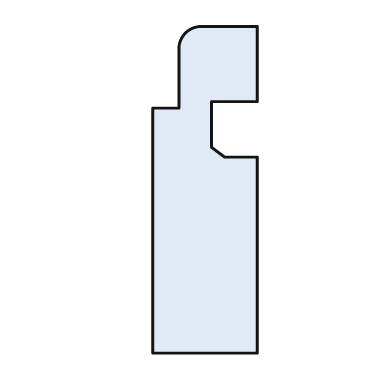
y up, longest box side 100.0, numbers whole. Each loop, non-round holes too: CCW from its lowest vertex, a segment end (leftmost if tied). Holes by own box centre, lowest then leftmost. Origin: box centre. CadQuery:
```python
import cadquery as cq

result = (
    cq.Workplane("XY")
    .moveTo(-16.0, -50.0)
    .lineTo(16.0, -50.0)
    .lineTo(16.0, 10.0)
    .lineTo(6.0, 10.0)
    .lineTo(2.0, 13.0)
    .lineTo(2.0, 27.0)
    .lineTo(16.0, 27.0)
    .lineTo(16.0, 50.0)
    .lineTo(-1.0, 50.0)
    .threePointArc((-6.0, 48.0), (-8.0, 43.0))
    .lineTo(-8.0, 25.0)
    .lineTo(-16.0, 25.0)
    .close()
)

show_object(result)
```